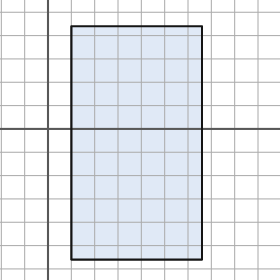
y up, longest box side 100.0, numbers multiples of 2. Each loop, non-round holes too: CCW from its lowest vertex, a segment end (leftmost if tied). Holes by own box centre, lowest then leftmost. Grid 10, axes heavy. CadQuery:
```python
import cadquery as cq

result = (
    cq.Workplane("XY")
    .moveTo(10.0, -56.0)
    .lineTo(66.0, -56.0)
    .lineTo(66.0, 44.0)
    .lineTo(10.0, 44.0)
    .close()
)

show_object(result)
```